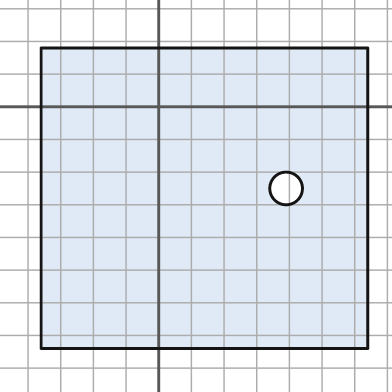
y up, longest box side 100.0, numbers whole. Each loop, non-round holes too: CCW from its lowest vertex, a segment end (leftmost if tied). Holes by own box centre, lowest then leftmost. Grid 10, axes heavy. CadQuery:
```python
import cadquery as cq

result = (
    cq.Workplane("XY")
    .moveTo(-36.0, -74.0)
    .lineTo(64.0, -74.0)
    .lineTo(64.0, 18.0)
    .lineTo(-36.0, 18.0)
    .close()
    .moveTo(39.0, -25.0)
    .circle(5.0)
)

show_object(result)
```